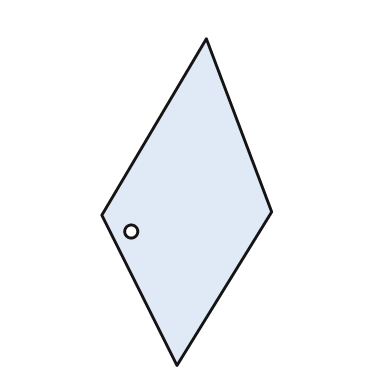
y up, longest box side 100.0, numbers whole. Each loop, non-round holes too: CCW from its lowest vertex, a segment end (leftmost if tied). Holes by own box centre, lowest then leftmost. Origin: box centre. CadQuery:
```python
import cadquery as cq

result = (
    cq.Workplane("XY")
    .moveTo(-3.0, -50.0)
    .lineTo(26.0, -3.0)
    .lineTo(6.0, 50.0)
    .lineTo(-26.0, -4.0)
    .close()
    .moveTo(-17.0, -9.0)
    .circle(2.0)
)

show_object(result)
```